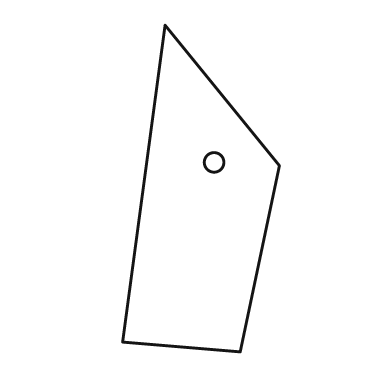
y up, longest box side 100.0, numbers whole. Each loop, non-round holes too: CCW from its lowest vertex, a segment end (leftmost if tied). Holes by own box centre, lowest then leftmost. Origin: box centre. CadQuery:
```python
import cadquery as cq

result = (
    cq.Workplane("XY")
    .moveTo(12.0, -50.0)
    .lineTo(24.0, 7.0)
    .lineTo(-11.0, 50.0)
    .lineTo(-24.0, -47.0)
    .close()
    .moveTo(4.0, 8.0)
    .circle(3.0)
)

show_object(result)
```